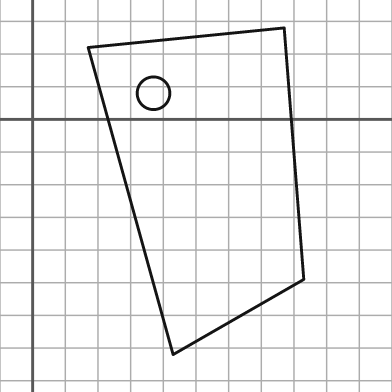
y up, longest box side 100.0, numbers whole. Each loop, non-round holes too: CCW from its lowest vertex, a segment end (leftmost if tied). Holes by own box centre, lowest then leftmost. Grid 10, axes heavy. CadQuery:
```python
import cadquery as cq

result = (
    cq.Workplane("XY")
    .moveTo(43.0, -72.0)
    .lineTo(83.0, -49.0)
    .lineTo(77.0, 28.0)
    .lineTo(17.0, 22.0)
    .close()
    .moveTo(37.0, 8.0)
    .circle(5.0)
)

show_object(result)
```